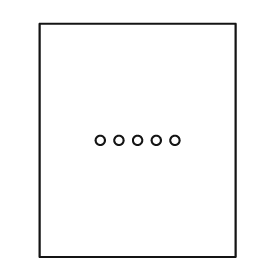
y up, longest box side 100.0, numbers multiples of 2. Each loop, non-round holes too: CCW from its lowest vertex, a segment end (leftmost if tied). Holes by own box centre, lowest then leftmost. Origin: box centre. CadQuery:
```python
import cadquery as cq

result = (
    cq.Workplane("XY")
    .moveTo(-42.0, -50.0)
    .lineTo(42.0, -50.0)
    .lineTo(42.0, 50.0)
    .lineTo(-42.0, 50.0)
    .close()
    .moveTo(-16.0, 0.0)
    .circle(2.0)
    .moveTo(-8.0, 0.0)
    .circle(2.0)
    .moveTo(0.0, 0.0)
    .circle(2.0)
    .moveTo(8.0, 0.0)
    .circle(2.0)
    .moveTo(16.0, 0.0)
    .circle(2.0)
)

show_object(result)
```